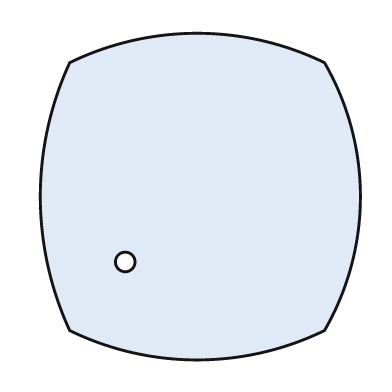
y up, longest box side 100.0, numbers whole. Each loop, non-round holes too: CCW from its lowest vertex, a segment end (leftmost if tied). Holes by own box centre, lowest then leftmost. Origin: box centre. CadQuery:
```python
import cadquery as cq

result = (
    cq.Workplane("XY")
    .moveTo(-40.0, -41.0)
    .threePointArc((-1.0, -50.0), (38.0, -41.0))
    .threePointArc((49.0, 0.0), (38.0, 41.0))
    .threePointArc((-1.0, 50.0), (-40.0, 41.0))
    .threePointArc((-49.0, 0.0), (-40.0, -41.0))
    .close()
    .moveTo(-23.0, -20.0)
    .circle(3.0)
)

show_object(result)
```